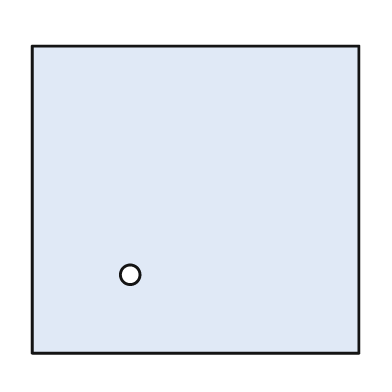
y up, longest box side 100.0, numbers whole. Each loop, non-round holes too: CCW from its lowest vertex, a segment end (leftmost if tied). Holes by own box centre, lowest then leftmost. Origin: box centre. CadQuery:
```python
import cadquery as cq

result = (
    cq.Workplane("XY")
    .moveTo(-50.0, -47.0)
    .lineTo(50.0, -47.0)
    .lineTo(50.0, 47.0)
    .lineTo(-50.0, 47.0)
    .close()
    .moveTo(-20.0, -23.0)
    .circle(3.0)
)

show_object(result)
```